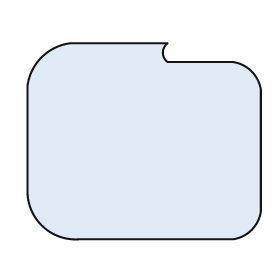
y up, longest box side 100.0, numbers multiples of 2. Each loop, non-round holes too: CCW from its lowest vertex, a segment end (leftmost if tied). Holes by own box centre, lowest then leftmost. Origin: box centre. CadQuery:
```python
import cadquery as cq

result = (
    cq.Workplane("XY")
    .moveTo(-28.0, -42.0)
    .lineTo(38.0, -42.0)
    .threePointArc((46.0, -38.0), (50.0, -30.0))
    .lineTo(50.0, 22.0)
    .threePointArc((46.0, 30.0), (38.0, 34.0))
    .lineTo(10.0, 34.0)
    .threePointArc((8.0, 38.0), (10.0, 42.0))
    .lineTo(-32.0, 42.0)
    .threePointArc((-44.0, 36.0), (-50.0, 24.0))
    .lineTo(-50.0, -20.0)
    .threePointArc((-44.0, -36.0), (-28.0, -42.0))
    .close()
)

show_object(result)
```